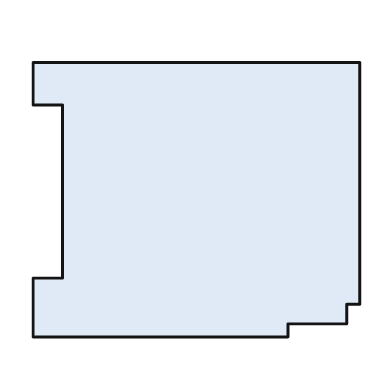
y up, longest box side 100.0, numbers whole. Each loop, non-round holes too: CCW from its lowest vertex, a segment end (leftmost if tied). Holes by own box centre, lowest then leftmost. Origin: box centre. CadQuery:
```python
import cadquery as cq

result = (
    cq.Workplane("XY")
    .moveTo(-50.0, -42.0)
    .lineTo(28.0, -42.0)
    .lineTo(28.0, -38.0)
    .lineTo(46.0, -38.0)
    .lineTo(46.0, -32.0)
    .lineTo(50.0, -32.0)
    .lineTo(50.0, 42.0)
    .lineTo(-50.0, 42.0)
    .lineTo(-50.0, 29.0)
    .lineTo(-41.0, 29.0)
    .lineTo(-41.0, -24.0)
    .lineTo(-50.0, -24.0)
    .close()
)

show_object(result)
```